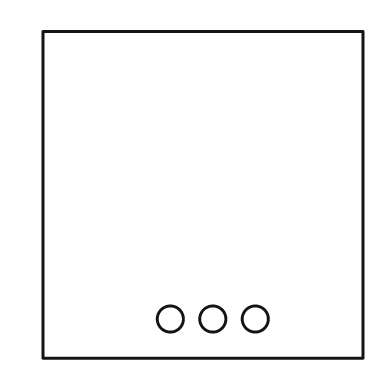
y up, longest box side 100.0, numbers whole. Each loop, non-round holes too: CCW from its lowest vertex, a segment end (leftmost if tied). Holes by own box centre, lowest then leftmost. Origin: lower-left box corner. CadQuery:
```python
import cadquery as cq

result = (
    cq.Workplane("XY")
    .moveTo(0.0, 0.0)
    .lineTo(98.0, 0.0)
    .lineTo(98.0, 100.0)
    .lineTo(0.0, 100.0)
    .close()
    .moveTo(39.0, 12.0)
    .circle(4.0)
    .moveTo(52.0, 12.0)
    .circle(4.0)
    .moveTo(65.0, 12.0)
    .circle(4.0)
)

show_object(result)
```